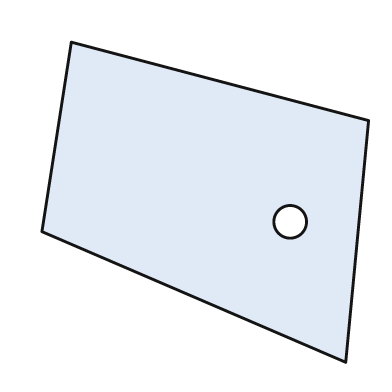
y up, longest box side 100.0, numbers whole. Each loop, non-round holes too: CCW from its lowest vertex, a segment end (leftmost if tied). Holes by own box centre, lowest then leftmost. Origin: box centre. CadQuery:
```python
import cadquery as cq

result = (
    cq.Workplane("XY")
    .moveTo(43.0, -49.0)
    .lineTo(50.0, 25.0)
    .lineTo(-41.0, 49.0)
    .lineTo(-50.0, -9.0)
    .close()
    .moveTo(26.0, -6.0)
    .circle(5.0)
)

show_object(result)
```